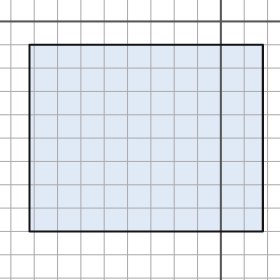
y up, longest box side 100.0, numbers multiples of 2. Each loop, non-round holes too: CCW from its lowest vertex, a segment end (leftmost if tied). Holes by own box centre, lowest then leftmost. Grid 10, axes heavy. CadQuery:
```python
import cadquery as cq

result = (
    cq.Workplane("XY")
    .moveTo(-82.0, -90.0)
    .lineTo(18.0, -90.0)
    .lineTo(18.0, -10.0)
    .lineTo(-82.0, -10.0)
    .close()
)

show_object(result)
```